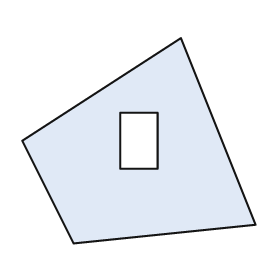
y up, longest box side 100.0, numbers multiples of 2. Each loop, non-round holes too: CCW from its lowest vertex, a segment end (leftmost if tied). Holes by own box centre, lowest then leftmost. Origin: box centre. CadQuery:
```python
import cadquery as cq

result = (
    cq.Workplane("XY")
    .moveTo(-28.0, -44.0)
    .lineTo(50.0, -36.0)
    .lineTo(18.0, 44.0)
    .lineTo(-50.0, 0.0)
    .close()
    .moveTo(-8.0, -12.0)
    .lineTo(8.0, -12.0)
    .lineTo(8.0, 12.0)
    .lineTo(-8.0, 12.0)
    .close()
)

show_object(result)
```